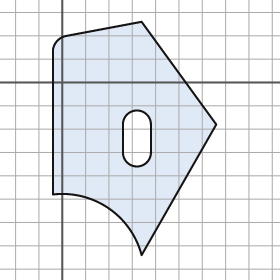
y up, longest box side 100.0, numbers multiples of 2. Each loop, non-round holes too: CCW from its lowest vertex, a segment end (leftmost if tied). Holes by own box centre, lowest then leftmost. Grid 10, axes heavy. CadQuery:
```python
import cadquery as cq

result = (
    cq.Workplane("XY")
    .moveTo(34.0, -74.0)
    .lineTo(66.0, -18.0)
    .lineTo(34.0, 26.0)
    .lineTo(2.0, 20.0)
    .threePointArc((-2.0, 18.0), (-4.0, 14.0))
    .lineTo(-4.0, -48.0)
    .threePointArc((20.0, -54.0), (34.0, -74.0))
    .close()
    .moveTo(26.0, -30.0)
    .threePointArc((32.0, -36.0), (38.0, -30.0))
    .lineTo(38.0, -18.0)
    .threePointArc((32.0, -12.0), (26.0, -18.0))
    .close()
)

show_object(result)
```